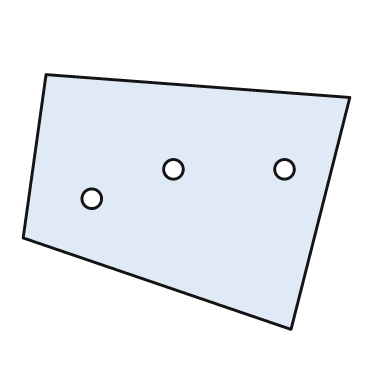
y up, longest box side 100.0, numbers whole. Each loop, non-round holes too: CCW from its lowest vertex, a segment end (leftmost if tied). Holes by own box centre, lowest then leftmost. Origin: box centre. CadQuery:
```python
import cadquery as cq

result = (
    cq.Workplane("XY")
    .moveTo(32.0, -39.0)
    .lineTo(50.0, 32.0)
    .lineTo(-43.0, 39.0)
    .lineTo(-50.0, -11.0)
    .close()
    .moveTo(-29.0, 1.0)
    .circle(3.0)
    .moveTo(-4.0, 10.0)
    .circle(3.0)
    .moveTo(30.0, 10.0)
    .circle(3.0)
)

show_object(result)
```